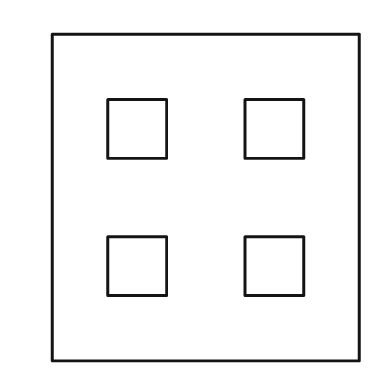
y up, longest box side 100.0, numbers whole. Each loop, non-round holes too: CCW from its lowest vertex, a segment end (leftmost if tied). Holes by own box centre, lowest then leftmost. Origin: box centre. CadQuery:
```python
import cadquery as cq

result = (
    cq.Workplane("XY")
    .moveTo(-47.0, -50.0)
    .lineTo(47.0, -50.0)
    .lineTo(47.0, 50.0)
    .lineTo(-47.0, 50.0)
    .close()
    .moveTo(-30.0, -30.0)
    .lineTo(-12.0, -30.0)
    .lineTo(-12.0, -12.0)
    .lineTo(-30.0, -12.0)
    .close()
    .moveTo(12.0, -30.0)
    .lineTo(30.0, -30.0)
    .lineTo(30.0, -12.0)
    .lineTo(12.0, -12.0)
    .close()
    .moveTo(-30.0, 12.0)
    .lineTo(-12.0, 12.0)
    .lineTo(-12.0, 30.0)
    .lineTo(-30.0, 30.0)
    .close()
    .moveTo(12.0, 12.0)
    .lineTo(30.0, 12.0)
    .lineTo(30.0, 30.0)
    .lineTo(12.0, 30.0)
    .close()
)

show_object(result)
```